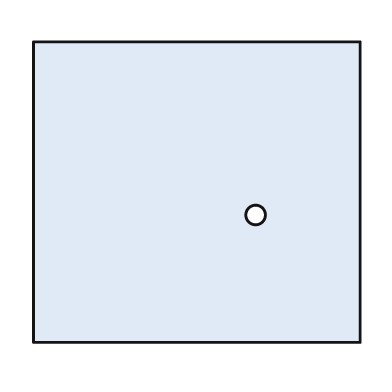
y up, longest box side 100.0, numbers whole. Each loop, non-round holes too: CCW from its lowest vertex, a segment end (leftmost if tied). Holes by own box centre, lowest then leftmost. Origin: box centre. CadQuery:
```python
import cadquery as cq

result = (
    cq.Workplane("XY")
    .moveTo(-50.0, -46.0)
    .lineTo(50.0, -46.0)
    .lineTo(50.0, 46.0)
    .lineTo(-50.0, 46.0)
    .close()
    .moveTo(18.0, -7.0)
    .circle(3.0)
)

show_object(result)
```